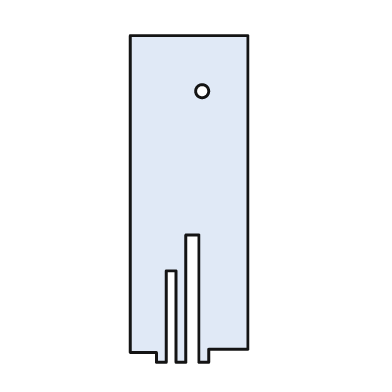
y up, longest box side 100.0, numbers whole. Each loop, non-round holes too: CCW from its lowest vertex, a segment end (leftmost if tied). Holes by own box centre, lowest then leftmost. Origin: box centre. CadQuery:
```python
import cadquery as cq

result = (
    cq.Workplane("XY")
    .moveTo(-10.0, -50.0)
    .lineTo(-7.0, -50.0)
    .lineTo(-7.0, -22.0)
    .lineTo(-4.0, -22.0)
    .lineTo(-4.0, -50.0)
    .lineTo(-1.0, -50.0)
    .lineTo(-1.0, -11.0)
    .lineTo(3.0, -11.0)
    .lineTo(3.0, -50.0)
    .lineTo(6.0, -50.0)
    .lineTo(6.0, -46.0)
    .lineTo(18.0, -46.0)
    .lineTo(18.0, 50.0)
    .lineTo(-18.0, 50.0)
    .lineTo(-18.0, -47.0)
    .lineTo(-10.0, -47.0)
    .close()
    .moveTo(4.0, 33.0)
    .circle(2.0)
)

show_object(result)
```